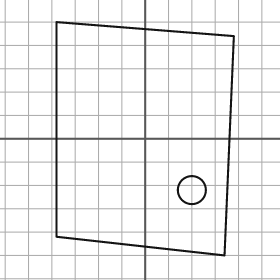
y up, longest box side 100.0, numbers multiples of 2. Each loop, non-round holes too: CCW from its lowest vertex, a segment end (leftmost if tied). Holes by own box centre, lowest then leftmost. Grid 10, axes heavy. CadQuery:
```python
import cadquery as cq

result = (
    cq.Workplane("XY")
    .moveTo(34.0, -50.0)
    .lineTo(38.0, 44.0)
    .lineTo(-38.0, 50.0)
    .lineTo(-38.0, -42.0)
    .close()
    .moveTo(20.0, -22.0)
    .circle(6.0)
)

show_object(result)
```